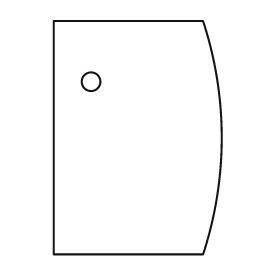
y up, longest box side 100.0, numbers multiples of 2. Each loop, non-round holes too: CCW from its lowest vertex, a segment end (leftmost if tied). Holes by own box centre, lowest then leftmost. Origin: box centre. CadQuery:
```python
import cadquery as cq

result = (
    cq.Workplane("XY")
    .moveTo(-36.0, -50.0)
    .lineTo(28.0, -50.0)
    .threePointArc((36.0, 0.0), (28.0, 50.0))
    .lineTo(-36.0, 50.0)
    .close()
    .moveTo(-20.0, 24.0)
    .circle(4.0)
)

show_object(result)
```